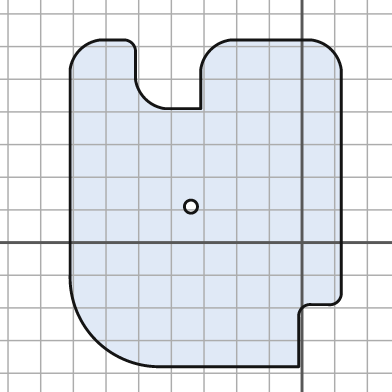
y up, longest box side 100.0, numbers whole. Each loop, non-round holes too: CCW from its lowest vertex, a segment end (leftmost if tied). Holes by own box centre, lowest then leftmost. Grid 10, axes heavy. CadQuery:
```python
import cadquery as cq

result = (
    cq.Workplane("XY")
    .moveTo(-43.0, -38.0)
    .lineTo(-1.0, -38.0)
    .lineTo(-1.0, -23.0)
    .threePointArc((0.0, -20.0), (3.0, -19.0))
    .lineTo(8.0, -19.0)
    .threePointArc((11.0, -18.0), (12.0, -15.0))
    .lineTo(12.0, 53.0)
    .threePointArc((9.0, 59.0), (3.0, 62.0))
    .lineTo(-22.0, 62.0)
    .threePointArc((-28.0, 59.0), (-31.0, 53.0))
    .lineTo(-31.0, 41.0)
    .lineTo(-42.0, 41.0)
    .threePointArc((-48.0, 44.0), (-51.0, 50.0))
    .lineTo(-51.0, 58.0)
    .threePointArc((-52.0, 61.0), (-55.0, 62.0))
    .lineTo(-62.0, 62.0)
    .threePointArc((-68.0, 59.0), (-71.0, 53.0))
    .lineTo(-71.0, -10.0)
    .threePointArc((-63.0, -30.0), (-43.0, -38.0))
    .close()
    .moveTo(-34.0, 11.0)
    .circle(2.0)
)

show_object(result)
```